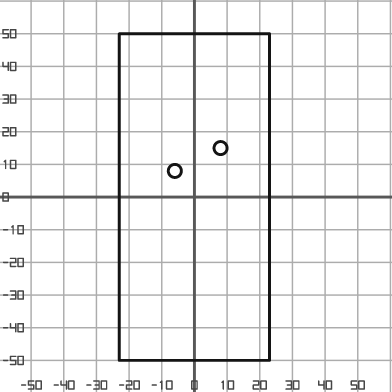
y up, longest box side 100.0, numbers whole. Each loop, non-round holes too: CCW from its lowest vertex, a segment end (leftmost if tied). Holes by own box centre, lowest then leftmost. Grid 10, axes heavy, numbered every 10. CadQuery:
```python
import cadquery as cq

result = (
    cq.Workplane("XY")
    .moveTo(-23.0, -50.0)
    .lineTo(23.0, -50.0)
    .lineTo(23.0, 50.0)
    .lineTo(-23.0, 50.0)
    .close()
    .moveTo(-6.0, 8.0)
    .circle(2.0)
    .moveTo(8.0, 15.0)
    .circle(2.0)
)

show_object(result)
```